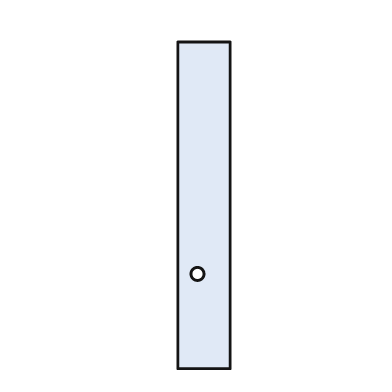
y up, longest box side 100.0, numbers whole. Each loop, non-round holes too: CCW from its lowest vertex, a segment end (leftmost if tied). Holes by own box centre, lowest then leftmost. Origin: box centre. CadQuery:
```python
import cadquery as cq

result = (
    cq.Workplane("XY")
    .moveTo(-8.0, -50.0)
    .lineTo(8.0, -50.0)
    .lineTo(8.0, 50.0)
    .lineTo(-8.0, 50.0)
    .close()
    .moveTo(-2.0, -21.0)
    .circle(2.0)
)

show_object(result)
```